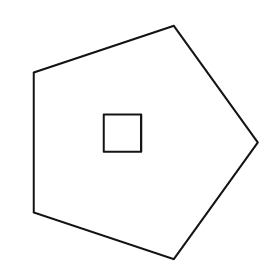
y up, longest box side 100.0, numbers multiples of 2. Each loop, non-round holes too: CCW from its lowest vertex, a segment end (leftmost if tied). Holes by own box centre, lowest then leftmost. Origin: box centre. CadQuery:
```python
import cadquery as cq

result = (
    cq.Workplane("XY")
    .moveTo(12.0, -50.0)
    .lineTo(48.0, 0.0)
    .lineTo(12.0, 50.0)
    .lineTo(-48.0, 30.0)
    .lineTo(-48.0, -30.0)
    .close()
    .moveTo(-18.0, -4.0)
    .lineTo(-2.0, -4.0)
    .lineTo(-2.0, 12.0)
    .lineTo(-18.0, 12.0)
    .close()
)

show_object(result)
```